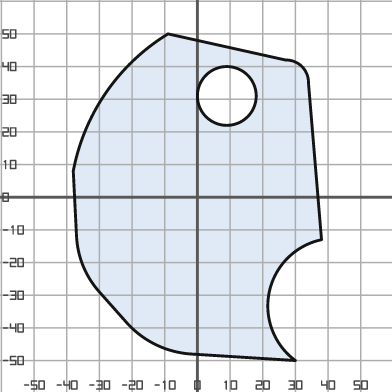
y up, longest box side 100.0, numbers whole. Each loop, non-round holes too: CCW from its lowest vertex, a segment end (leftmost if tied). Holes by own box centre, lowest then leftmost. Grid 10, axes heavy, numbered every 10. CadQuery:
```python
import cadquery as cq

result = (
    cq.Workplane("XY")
    .moveTo(30.0, -50.0)
    .threePointArc((22.0, -29.0), (38.0, -13.0))
    .lineTo(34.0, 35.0)
    .threePointArc((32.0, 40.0), (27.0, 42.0))
    .lineTo(-9.0, 50.0)
    .threePointArc((-28.0, 32.0), (-38.0, 8.0))
    .lineTo(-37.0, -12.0)
    .threePointArc((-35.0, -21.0), (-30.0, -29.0))
    .lineTo(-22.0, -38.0)
    .threePointArc((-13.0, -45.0), (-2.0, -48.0))
    .close()
    .moveTo(9.0, 31.0)
    .circle(9.0)
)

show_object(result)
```